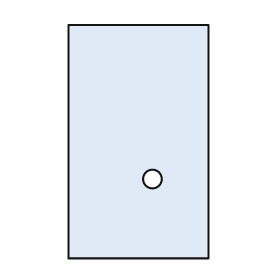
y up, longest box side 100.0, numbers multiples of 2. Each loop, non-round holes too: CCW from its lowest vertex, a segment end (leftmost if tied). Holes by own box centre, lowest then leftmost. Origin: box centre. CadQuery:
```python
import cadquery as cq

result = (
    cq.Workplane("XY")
    .moveTo(-30.0, -50.0)
    .lineTo(30.0, -50.0)
    .lineTo(30.0, 50.0)
    .lineTo(-30.0, 50.0)
    .close()
    .moveTo(6.0, -16.0)
    .circle(4.0)
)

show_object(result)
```